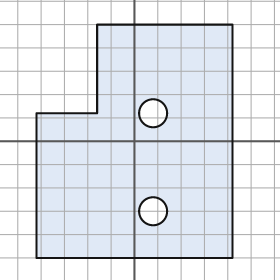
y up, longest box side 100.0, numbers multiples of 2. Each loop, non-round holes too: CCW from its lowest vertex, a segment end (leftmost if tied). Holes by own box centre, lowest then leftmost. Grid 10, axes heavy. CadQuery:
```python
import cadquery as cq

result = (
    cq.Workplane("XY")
    .moveTo(-42.0, -50.0)
    .lineTo(42.0, -50.0)
    .lineTo(42.0, 50.0)
    .lineTo(-16.0, 50.0)
    .lineTo(-16.0, 12.0)
    .lineTo(-42.0, 12.0)
    .close()
    .moveTo(8.0, -30.0)
    .circle(6.0)
    .moveTo(8.0, 12.0)
    .circle(6.0)
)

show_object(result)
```